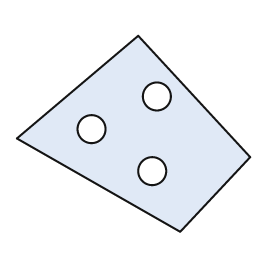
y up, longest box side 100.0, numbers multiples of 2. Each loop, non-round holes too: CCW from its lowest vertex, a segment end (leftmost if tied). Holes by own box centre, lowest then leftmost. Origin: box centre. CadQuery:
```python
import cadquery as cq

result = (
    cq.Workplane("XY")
    .moveTo(20.0, -42.0)
    .lineTo(50.0, -10.0)
    .lineTo(2.0, 42.0)
    .lineTo(-50.0, -2.0)
    .close()
    .moveTo(8.0, -16.0)
    .circle(6.0)
    .moveTo(-18.0, 2.0)
    .circle(6.0)
    .moveTo(10.0, 16.0)
    .circle(6.0)
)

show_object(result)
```